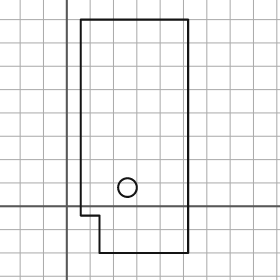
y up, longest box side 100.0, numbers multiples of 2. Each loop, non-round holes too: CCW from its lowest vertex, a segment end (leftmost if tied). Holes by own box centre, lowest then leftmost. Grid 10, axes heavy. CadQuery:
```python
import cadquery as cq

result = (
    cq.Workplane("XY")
    .moveTo(14.0, -20.0)
    .lineTo(52.0, -20.0)
    .lineTo(52.0, 80.0)
    .lineTo(6.0, 80.0)
    .lineTo(6.0, -4.0)
    .lineTo(14.0, -4.0)
    .close()
    .moveTo(26.0, 8.0)
    .circle(4.0)
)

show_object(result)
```